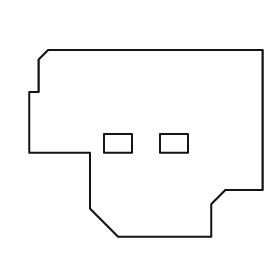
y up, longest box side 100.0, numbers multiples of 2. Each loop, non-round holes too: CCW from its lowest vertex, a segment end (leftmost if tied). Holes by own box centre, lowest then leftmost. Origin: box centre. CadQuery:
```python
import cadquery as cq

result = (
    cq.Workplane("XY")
    .moveTo(-12.0, -40.0)
    .lineTo(28.0, -40.0)
    .lineTo(28.0, -26.0)
    .lineTo(34.0, -20.0)
    .lineTo(50.0, -20.0)
    .lineTo(50.0, 40.0)
    .lineTo(-42.0, 40.0)
    .lineTo(-46.0, 36.0)
    .lineTo(-46.0, 22.0)
    .lineTo(-50.0, 22.0)
    .lineTo(-50.0, -4.0)
    .lineTo(-24.0, -4.0)
    .lineTo(-24.0, -28.0)
    .close()
    .moveTo(-18.0, -4.0)
    .lineTo(-6.0, -4.0)
    .lineTo(-6.0, 4.0)
    .lineTo(-18.0, 4.0)
    .close()
    .moveTo(6.0, -4.0)
    .lineTo(18.0, -4.0)
    .lineTo(18.0, 4.0)
    .lineTo(6.0, 4.0)
    .close()
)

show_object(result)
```